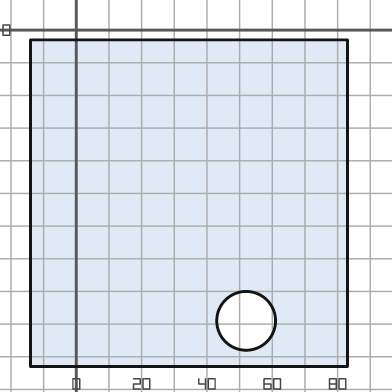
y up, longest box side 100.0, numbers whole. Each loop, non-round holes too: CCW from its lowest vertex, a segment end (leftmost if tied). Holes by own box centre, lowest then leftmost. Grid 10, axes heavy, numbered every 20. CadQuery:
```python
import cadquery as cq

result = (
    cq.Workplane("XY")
    .moveTo(-14.0, -103.0)
    .lineTo(83.0, -103.0)
    .lineTo(83.0, -3.0)
    .lineTo(-14.0, -3.0)
    .close()
    .moveTo(52.0, -89.0)
    .circle(9.0)
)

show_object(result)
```